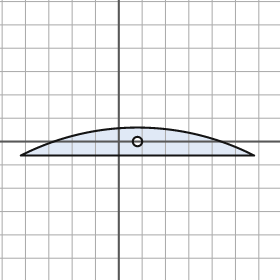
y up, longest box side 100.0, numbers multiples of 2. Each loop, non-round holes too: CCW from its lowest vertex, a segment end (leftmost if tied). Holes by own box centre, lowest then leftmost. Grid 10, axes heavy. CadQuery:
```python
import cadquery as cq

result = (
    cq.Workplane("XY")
    .moveTo(-42.0, -6.0)
    .lineTo(58.0, -6.0)
    .threePointArc((8.0, 6.0), (-42.0, -6.0))
    .close()
    .moveTo(8.0, 0.0)
    .circle(2.0)
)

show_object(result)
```